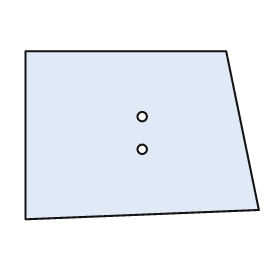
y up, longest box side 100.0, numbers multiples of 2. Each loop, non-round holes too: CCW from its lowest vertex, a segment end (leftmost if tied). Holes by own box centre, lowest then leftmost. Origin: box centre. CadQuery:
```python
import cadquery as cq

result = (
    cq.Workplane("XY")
    .moveTo(-50.0, -36.0)
    .lineTo(50.0, -32.0)
    .lineTo(36.0, 36.0)
    .lineTo(-50.0, 36.0)
    .close()
    .moveTo(0.0, -6.0)
    .circle(2.0)
    .moveTo(0.0, 8.0)
    .circle(2.0)
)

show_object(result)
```